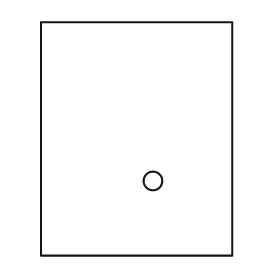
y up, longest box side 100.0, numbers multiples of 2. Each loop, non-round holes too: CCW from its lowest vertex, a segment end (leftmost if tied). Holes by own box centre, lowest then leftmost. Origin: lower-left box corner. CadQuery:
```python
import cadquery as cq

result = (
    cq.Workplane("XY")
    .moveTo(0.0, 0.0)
    .lineTo(82.0, 0.0)
    .lineTo(82.0, 100.0)
    .lineTo(0.0, 100.0)
    .close()
    .moveTo(48.0, 32.0)
    .circle(4.0)
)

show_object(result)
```